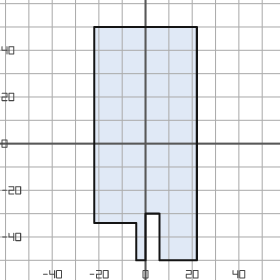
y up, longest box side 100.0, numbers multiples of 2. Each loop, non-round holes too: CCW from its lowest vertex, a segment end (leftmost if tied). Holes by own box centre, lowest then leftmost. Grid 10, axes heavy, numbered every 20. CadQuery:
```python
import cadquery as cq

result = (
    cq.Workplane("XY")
    .moveTo(-4.0, -50.0)
    .lineTo(0.0, -50.0)
    .lineTo(0.0, -30.0)
    .lineTo(6.0, -30.0)
    .lineTo(6.0, -50.0)
    .lineTo(22.0, -50.0)
    .lineTo(22.0, 50.0)
    .lineTo(-22.0, 50.0)
    .lineTo(-22.0, -34.0)
    .lineTo(-4.0, -34.0)
    .close()
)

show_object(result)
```